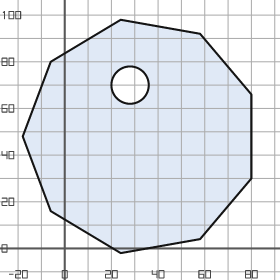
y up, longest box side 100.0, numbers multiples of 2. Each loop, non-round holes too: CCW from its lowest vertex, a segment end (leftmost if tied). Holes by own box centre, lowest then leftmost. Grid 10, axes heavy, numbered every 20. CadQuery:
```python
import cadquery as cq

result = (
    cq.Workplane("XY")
    .moveTo(24.0, -2.0)
    .lineTo(58.0, 4.0)
    .lineTo(80.0, 30.0)
    .lineTo(80.0, 66.0)
    .lineTo(58.0, 92.0)
    .lineTo(24.0, 98.0)
    .lineTo(-6.0, 80.0)
    .lineTo(-18.0, 48.0)
    .lineTo(-6.0, 16.0)
    .close()
    .moveTo(28.0, 70.0)
    .circle(8.0)
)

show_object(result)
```